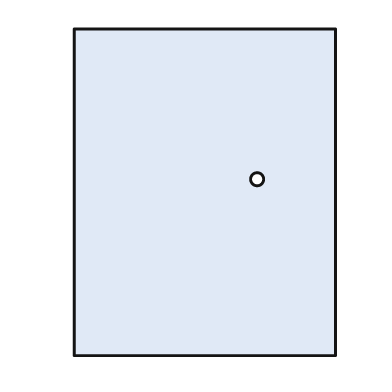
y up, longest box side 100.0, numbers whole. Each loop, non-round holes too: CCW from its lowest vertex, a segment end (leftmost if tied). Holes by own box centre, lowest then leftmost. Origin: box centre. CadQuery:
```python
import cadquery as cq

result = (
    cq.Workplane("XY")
    .moveTo(-40.0, -50.0)
    .lineTo(40.0, -50.0)
    .lineTo(40.0, 50.0)
    .lineTo(-40.0, 50.0)
    .close()
    .moveTo(16.0, 4.0)
    .circle(2.0)
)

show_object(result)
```